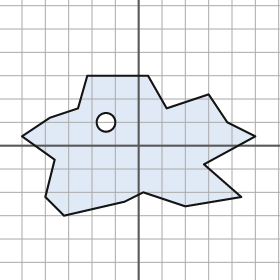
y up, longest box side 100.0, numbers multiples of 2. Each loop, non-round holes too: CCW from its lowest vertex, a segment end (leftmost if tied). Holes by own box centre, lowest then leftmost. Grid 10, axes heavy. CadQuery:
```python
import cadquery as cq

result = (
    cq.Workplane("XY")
    .moveTo(-32.0, -30.0)
    .lineTo(-6.0, -24.0)
    .lineTo(2.0, -20.0)
    .lineTo(20.0, -26.0)
    .lineTo(44.0, -22.0)
    .lineTo(28.0, -8.0)
    .lineTo(50.0, 4.0)
    .lineTo(38.0, 10.0)
    .lineTo(30.0, 22.0)
    .lineTo(12.0, 16.0)
    .lineTo(4.0, 30.0)
    .lineTo(-22.0, 30.0)
    .lineTo(-26.0, 16.0)
    .lineTo(-38.0, 12.0)
    .lineTo(-50.0, 4.0)
    .lineTo(-36.0, -6.0)
    .lineTo(-40.0, -22.0)
    .close()
    .moveTo(-14.0, 10.0)
    .circle(4.0)
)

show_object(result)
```